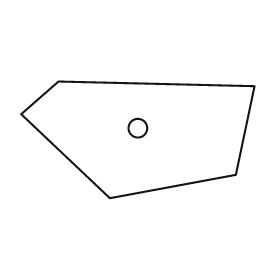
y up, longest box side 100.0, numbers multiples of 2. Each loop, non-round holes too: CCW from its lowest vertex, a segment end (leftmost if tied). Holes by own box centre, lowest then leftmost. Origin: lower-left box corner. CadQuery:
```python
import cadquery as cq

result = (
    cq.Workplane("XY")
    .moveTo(38.0, 0.0)
    .lineTo(92.0, 10.0)
    .lineTo(100.0, 48.0)
    .lineTo(16.0, 50.0)
    .lineTo(0.0, 36.0)
    .close()
    .moveTo(50.0, 30.0)
    .circle(4.0)
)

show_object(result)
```